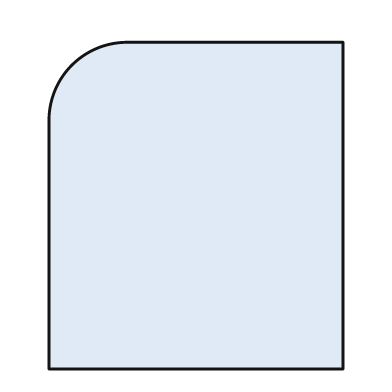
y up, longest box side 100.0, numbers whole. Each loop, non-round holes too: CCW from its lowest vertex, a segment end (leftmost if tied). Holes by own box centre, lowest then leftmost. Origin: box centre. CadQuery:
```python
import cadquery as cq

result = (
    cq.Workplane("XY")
    .moveTo(-45.0, -50.0)
    .lineTo(45.0, -50.0)
    .lineTo(45.0, 50.0)
    .lineTo(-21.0, 50.0)
    .threePointArc((-38.0, 43.0), (-45.0, 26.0))
    .close()
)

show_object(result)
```